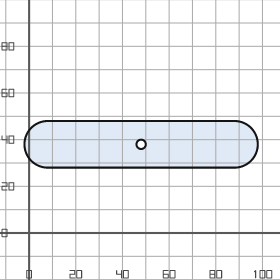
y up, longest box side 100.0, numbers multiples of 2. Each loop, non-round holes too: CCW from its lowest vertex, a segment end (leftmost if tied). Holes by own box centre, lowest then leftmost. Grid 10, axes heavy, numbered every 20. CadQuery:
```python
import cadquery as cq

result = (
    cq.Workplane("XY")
    .moveTo(8.0, 28.0)
    .lineTo(88.0, 28.0)
    .threePointArc((98.0, 38.0), (88.0, 48.0))
    .lineTo(8.0, 48.0)
    .threePointArc((-2.0, 38.0), (8.0, 28.0))
    .close()
    .moveTo(48.0, 38.0)
    .circle(2.0)
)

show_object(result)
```